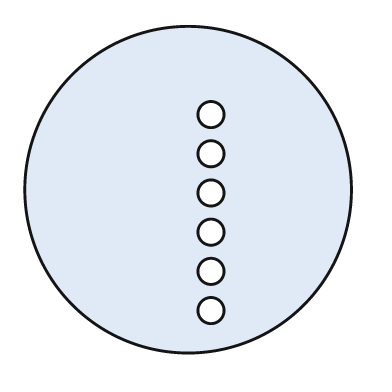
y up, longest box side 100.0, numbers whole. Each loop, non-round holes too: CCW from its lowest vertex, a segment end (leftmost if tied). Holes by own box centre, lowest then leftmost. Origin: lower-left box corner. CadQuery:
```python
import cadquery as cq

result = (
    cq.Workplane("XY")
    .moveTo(50.0, 50.0)
    .circle(50.0)
    .moveTo(57.0, 13.0)
    .circle(4.0)
    .moveTo(57.0, 25.0)
    .circle(4.0)
    .moveTo(57.0, 37.0)
    .circle(4.0)
    .moveTo(57.0, 49.0)
    .circle(4.0)
    .moveTo(57.0, 61.0)
    .circle(4.0)
    .moveTo(57.0, 73.0)
    .circle(4.0)
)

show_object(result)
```